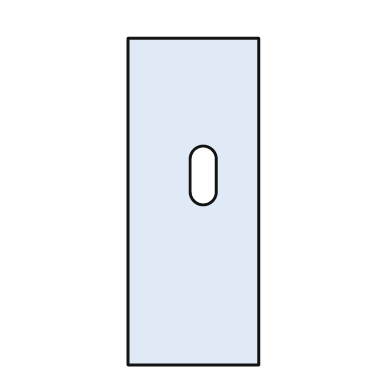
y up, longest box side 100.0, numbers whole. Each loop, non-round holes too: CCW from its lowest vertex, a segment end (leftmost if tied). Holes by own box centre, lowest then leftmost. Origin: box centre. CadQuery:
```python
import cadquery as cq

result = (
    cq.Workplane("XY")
    .moveTo(-20.0, -50.0)
    .lineTo(20.0, -50.0)
    .lineTo(20.0, 50.0)
    .lineTo(-20.0, 50.0)
    .close()
    .moveTo(-1.0, 3.0)
    .threePointArc((3.0, -1.0), (7.0, 3.0))
    .lineTo(7.0, 13.0)
    .threePointArc((3.0, 17.0), (-1.0, 13.0))
    .close()
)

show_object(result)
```